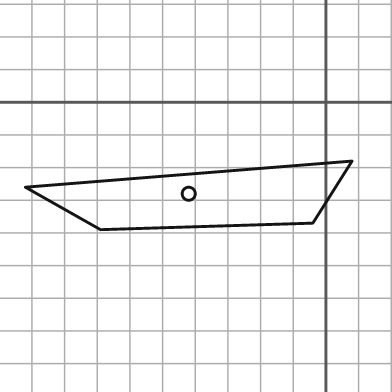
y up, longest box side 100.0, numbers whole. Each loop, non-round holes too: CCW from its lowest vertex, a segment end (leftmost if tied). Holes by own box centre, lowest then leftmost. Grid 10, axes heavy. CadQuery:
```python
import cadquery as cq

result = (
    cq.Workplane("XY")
    .moveTo(-69.0, -39.0)
    .lineTo(-4.0, -37.0)
    .lineTo(8.0, -18.0)
    .lineTo(-92.0, -26.0)
    .close()
    .moveTo(-42.0, -28.0)
    .circle(2.0)
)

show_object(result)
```